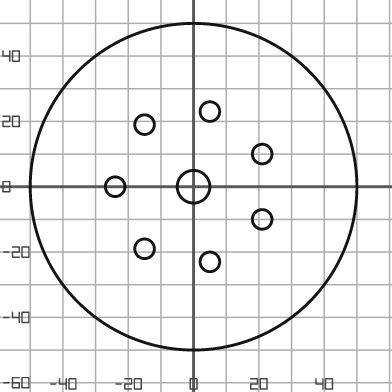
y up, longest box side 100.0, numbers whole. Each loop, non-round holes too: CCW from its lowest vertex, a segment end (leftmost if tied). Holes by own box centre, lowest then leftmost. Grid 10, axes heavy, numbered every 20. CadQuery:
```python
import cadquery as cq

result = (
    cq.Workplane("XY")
    .moveTo(0.0, 0.0)
    .circle(50.0)
    .moveTo(5.0, -23.0)
    .circle(3.0)
    .moveTo(-15.0, -19.0)
    .circle(3.0)
    .moveTo(21.0, -10.0)
    .circle(3.0)
    .moveTo(-24.0, 0.0)
    .circle(3.0)
    .moveTo(0.0, 0.0)
    .circle(5.0)
    .moveTo(21.0, 10.0)
    .circle(3.0)
    .moveTo(-15.0, 19.0)
    .circle(3.0)
    .moveTo(5.0, 23.0)
    .circle(3.0)
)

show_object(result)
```